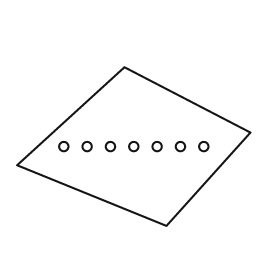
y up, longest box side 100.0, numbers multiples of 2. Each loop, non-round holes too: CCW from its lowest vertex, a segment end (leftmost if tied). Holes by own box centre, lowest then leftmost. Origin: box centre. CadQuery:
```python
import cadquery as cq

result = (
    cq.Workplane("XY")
    .moveTo(14.0, -34.0)
    .lineTo(50.0, 6.0)
    .lineTo(-4.0, 34.0)
    .lineTo(-50.0, -8.0)
    .close()
    .moveTo(-30.0, 0.0)
    .circle(2.0)
    .moveTo(-20.0, 0.0)
    .circle(2.0)
    .moveTo(-10.0, 0.0)
    .circle(2.0)
    .moveTo(0.0, 0.0)
    .circle(2.0)
    .moveTo(10.0, 0.0)
    .circle(2.0)
    .moveTo(20.0, 0.0)
    .circle(2.0)
    .moveTo(30.0, 0.0)
    .circle(2.0)
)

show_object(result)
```